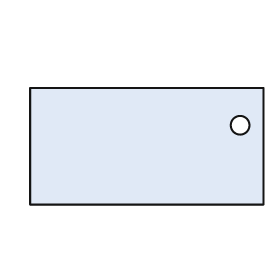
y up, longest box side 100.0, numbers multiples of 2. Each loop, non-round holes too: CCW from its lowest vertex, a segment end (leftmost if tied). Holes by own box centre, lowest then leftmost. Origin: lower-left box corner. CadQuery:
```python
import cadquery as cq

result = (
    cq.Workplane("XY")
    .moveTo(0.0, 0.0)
    .lineTo(100.0, 0.0)
    .lineTo(100.0, 50.0)
    .lineTo(0.0, 50.0)
    .close()
    .moveTo(90.0, 34.0)
    .circle(4.0)
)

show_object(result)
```